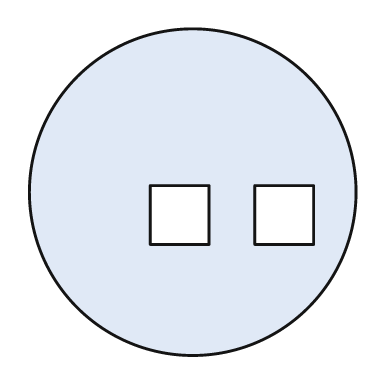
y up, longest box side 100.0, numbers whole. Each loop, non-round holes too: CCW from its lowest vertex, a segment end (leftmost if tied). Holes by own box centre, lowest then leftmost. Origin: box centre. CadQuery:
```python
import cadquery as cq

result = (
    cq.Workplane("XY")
    .moveTo(0.0, 0.0)
    .circle(50.0)
    .moveTo(-13.0, -16.0)
    .lineTo(5.0, -16.0)
    .lineTo(5.0, 2.0)
    .lineTo(-13.0, 2.0)
    .close()
    .moveTo(19.0, -16.0)
    .lineTo(37.0, -16.0)
    .lineTo(37.0, 2.0)
    .lineTo(19.0, 2.0)
    .close()
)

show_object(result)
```